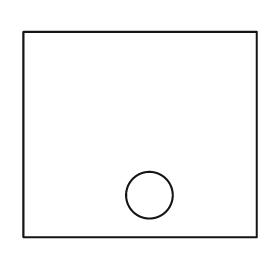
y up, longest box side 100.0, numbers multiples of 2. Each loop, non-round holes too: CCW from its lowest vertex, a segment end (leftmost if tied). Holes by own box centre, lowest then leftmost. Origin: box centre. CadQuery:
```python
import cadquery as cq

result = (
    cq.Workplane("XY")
    .moveTo(-50.0, -44.0)
    .lineTo(50.0, -44.0)
    .lineTo(50.0, 44.0)
    .lineTo(-50.0, 44.0)
    .close()
    .moveTo(4.0, -26.0)
    .circle(10.0)
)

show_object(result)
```